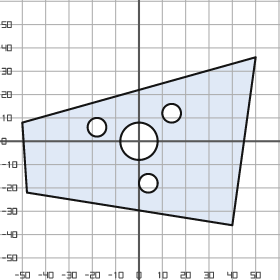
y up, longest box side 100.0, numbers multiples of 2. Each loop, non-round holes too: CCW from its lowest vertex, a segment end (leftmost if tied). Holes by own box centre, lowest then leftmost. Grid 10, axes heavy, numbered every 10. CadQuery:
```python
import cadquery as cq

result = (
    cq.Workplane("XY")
    .moveTo(40.0, -36.0)
    .lineTo(50.0, 36.0)
    .lineTo(-50.0, 8.0)
    .lineTo(-48.0, -22.0)
    .close()
    .moveTo(4.0, -18.0)
    .circle(4.0)
    .moveTo(0.0, 0.0)
    .circle(8.0)
    .moveTo(-18.0, 6.0)
    .circle(4.0)
    .moveTo(14.0, 12.0)
    .circle(4.0)
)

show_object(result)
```